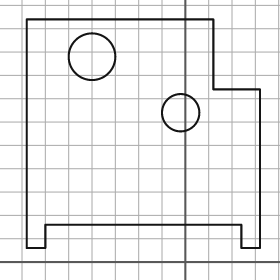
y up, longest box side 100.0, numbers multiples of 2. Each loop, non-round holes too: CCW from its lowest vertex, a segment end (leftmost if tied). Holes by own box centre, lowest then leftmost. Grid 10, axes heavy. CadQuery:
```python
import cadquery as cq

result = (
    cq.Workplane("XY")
    .moveTo(-68.0, 6.0)
    .lineTo(-60.0, 6.0)
    .lineTo(-60.0, 16.0)
    .lineTo(24.0, 16.0)
    .lineTo(24.0, 6.0)
    .lineTo(32.0, 6.0)
    .lineTo(32.0, 74.0)
    .lineTo(12.0, 74.0)
    .lineTo(12.0, 104.0)
    .lineTo(-68.0, 104.0)
    .close()
    .moveTo(-2.0, 64.0)
    .circle(8.0)
    .moveTo(-40.0, 88.0)
    .circle(10.0)
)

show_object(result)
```